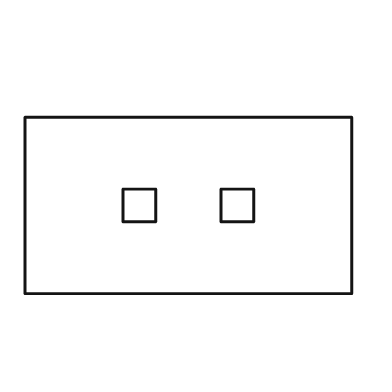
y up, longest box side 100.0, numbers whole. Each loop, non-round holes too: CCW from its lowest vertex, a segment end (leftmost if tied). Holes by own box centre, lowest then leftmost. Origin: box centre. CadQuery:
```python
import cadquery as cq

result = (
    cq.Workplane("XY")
    .moveTo(-50.0, -27.0)
    .lineTo(50.0, -27.0)
    .lineTo(50.0, 27.0)
    .lineTo(-50.0, 27.0)
    .close()
    .moveTo(-20.0, -5.0)
    .lineTo(-10.0, -5.0)
    .lineTo(-10.0, 5.0)
    .lineTo(-20.0, 5.0)
    .close()
    .moveTo(10.0, -5.0)
    .lineTo(20.0, -5.0)
    .lineTo(20.0, 5.0)
    .lineTo(10.0, 5.0)
    .close()
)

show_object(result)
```